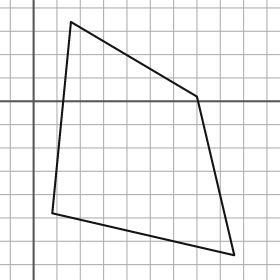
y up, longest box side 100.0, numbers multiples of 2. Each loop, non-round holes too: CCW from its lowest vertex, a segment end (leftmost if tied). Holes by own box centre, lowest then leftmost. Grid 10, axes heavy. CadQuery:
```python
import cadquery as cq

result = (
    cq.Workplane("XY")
    .moveTo(86.0, -66.0)
    .lineTo(70.0, 2.0)
    .lineTo(16.0, 34.0)
    .lineTo(8.0, -48.0)
    .close()
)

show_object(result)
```